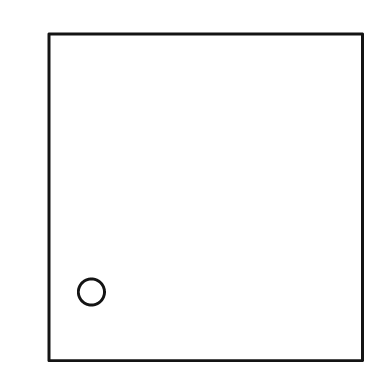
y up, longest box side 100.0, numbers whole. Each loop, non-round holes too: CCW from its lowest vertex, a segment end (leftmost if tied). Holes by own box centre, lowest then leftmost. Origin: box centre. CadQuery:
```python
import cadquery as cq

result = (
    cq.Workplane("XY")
    .moveTo(-48.0, -50.0)
    .lineTo(48.0, -50.0)
    .lineTo(48.0, 50.0)
    .lineTo(-48.0, 50.0)
    .close()
    .moveTo(-35.0, -29.0)
    .circle(4.0)
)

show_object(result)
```